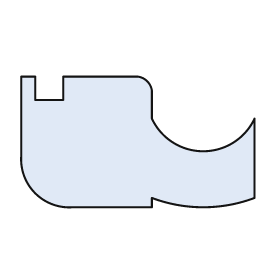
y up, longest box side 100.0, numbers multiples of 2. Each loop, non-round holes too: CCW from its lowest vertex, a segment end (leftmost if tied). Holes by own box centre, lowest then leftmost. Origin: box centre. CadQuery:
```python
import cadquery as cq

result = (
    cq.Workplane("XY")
    .moveTo(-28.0, -28.0)
    .lineTo(6.0, -28.0)
    .lineTo(6.0, -24.0)
    .threePointArc((28.0, -28.0), (50.0, -24.0))
    .lineTo(50.0, 10.0)
    .threePointArc((28.0, -4.0), (6.0, 10.0))
    .lineTo(6.0, 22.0)
    .threePointArc((4.0, 26.0), (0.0, 28.0))
    .lineTo(-32.0, 28.0)
    .lineTo(-32.0, 18.0)
    .lineTo(-44.0, 18.0)
    .lineTo(-44.0, 28.0)
    .lineTo(-50.0, 28.0)
    .lineTo(-50.0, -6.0)
    .threePointArc((-44.0, -22.0), (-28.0, -28.0))
    .close()
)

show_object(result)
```